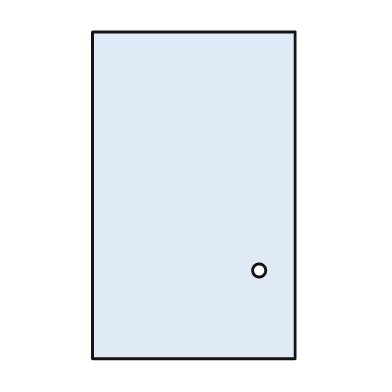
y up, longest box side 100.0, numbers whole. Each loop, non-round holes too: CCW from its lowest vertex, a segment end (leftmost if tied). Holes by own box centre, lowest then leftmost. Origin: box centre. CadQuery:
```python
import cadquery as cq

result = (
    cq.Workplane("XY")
    .moveTo(-31.0, -50.0)
    .lineTo(31.0, -50.0)
    .lineTo(31.0, 50.0)
    .lineTo(-31.0, 50.0)
    .close()
    .moveTo(20.0, -23.0)
    .circle(2.0)
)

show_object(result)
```